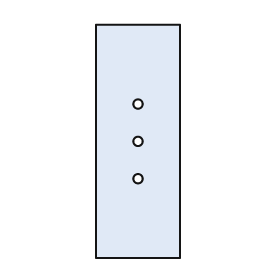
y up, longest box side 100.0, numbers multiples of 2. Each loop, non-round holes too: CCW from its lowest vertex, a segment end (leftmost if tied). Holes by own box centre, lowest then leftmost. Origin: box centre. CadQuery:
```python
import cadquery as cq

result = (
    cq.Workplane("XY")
    .moveTo(-18.0, -50.0)
    .lineTo(18.0, -50.0)
    .lineTo(18.0, 50.0)
    .lineTo(-18.0, 50.0)
    .close()
    .moveTo(0.0, -16.0)
    .circle(2.0)
    .moveTo(0.0, 0.0)
    .circle(2.0)
    .moveTo(0.0, 16.0)
    .circle(2.0)
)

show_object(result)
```